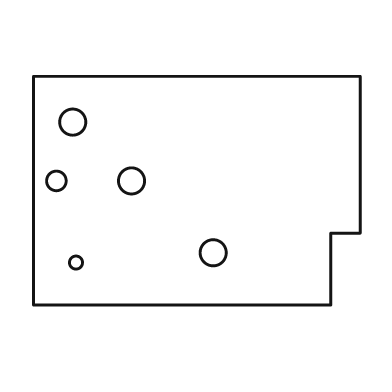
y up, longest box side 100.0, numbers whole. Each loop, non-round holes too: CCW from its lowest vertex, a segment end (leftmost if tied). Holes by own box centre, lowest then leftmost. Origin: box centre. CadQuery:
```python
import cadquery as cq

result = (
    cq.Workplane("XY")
    .moveTo(-50.0, -35.0)
    .lineTo(41.0, -35.0)
    .lineTo(41.0, -13.0)
    .lineTo(50.0, -13.0)
    .lineTo(50.0, 35.0)
    .lineTo(-50.0, 35.0)
    .close()
    .moveTo(-37.0, -22.0)
    .circle(2.0)
    .moveTo(5.0, -19.0)
    .circle(4.0)
    .moveTo(-43.0, 3.0)
    .circle(3.0)
    .moveTo(-20.0, 3.0)
    .circle(4.0)
    .moveTo(-38.0, 21.0)
    .circle(4.0)
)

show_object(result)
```